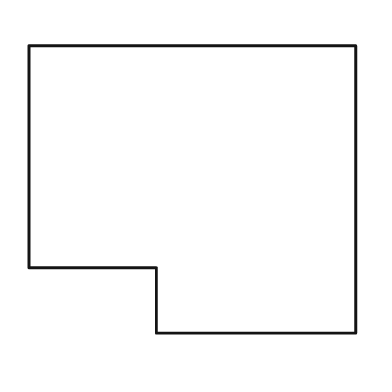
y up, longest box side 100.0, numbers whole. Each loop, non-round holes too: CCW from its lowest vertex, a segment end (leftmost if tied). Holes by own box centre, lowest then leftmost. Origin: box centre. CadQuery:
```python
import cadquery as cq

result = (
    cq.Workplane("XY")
    .moveTo(-11.0, -44.0)
    .lineTo(50.0, -44.0)
    .lineTo(50.0, 44.0)
    .lineTo(-50.0, 44.0)
    .lineTo(-50.0, -24.0)
    .lineTo(-11.0, -24.0)
    .close()
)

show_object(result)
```